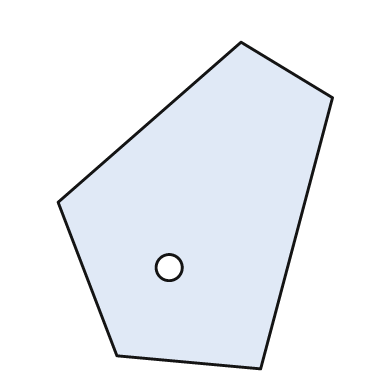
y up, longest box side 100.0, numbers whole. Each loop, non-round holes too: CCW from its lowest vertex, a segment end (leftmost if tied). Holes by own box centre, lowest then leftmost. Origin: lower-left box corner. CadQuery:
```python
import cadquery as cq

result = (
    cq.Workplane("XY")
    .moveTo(62.0, 0.0)
    .lineTo(84.0, 83.0)
    .lineTo(56.0, 100.0)
    .lineTo(0.0, 51.0)
    .lineTo(18.0, 4.0)
    .close()
    .moveTo(34.0, 31.0)
    .circle(4.0)
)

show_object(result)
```